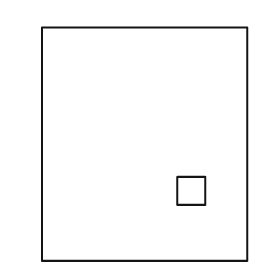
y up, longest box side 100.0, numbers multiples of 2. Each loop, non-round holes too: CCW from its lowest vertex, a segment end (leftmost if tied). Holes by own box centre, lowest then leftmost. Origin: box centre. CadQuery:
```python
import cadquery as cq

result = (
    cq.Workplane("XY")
    .moveTo(-44.0, -50.0)
    .lineTo(44.0, -50.0)
    .lineTo(44.0, 50.0)
    .lineTo(-44.0, 50.0)
    .close()
    .moveTo(14.0, -26.0)
    .lineTo(26.0, -26.0)
    .lineTo(26.0, -14.0)
    .lineTo(14.0, -14.0)
    .close()
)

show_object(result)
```